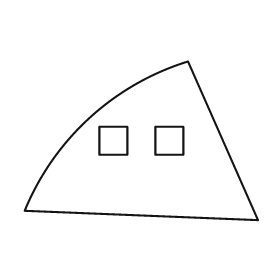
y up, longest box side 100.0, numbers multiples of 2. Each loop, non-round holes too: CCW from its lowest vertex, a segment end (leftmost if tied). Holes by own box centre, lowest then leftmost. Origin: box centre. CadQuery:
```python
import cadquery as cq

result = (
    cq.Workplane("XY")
    .moveTo(50.0, -34.0)
    .lineTo(20.0, 34.0)
    .threePointArc((-22.0, 10.0), (-50.0, -30.0))
    .close()
    .moveTo(-18.0, -6.0)
    .lineTo(-6.0, -6.0)
    .lineTo(-6.0, 6.0)
    .lineTo(-18.0, 6.0)
    .close()
    .moveTo(6.0, -6.0)
    .lineTo(18.0, -6.0)
    .lineTo(18.0, 6.0)
    .lineTo(6.0, 6.0)
    .close()
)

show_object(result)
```